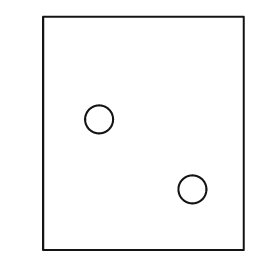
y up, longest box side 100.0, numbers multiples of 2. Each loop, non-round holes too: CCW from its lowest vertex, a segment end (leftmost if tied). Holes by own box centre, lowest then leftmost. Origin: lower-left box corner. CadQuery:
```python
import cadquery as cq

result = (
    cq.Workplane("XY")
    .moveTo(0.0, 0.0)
    .lineTo(86.0, 0.0)
    .lineTo(86.0, 100.0)
    .lineTo(0.0, 100.0)
    .close()
    .moveTo(64.0, 26.0)
    .circle(6.0)
    .moveTo(24.0, 56.0)
    .circle(6.0)
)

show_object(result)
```